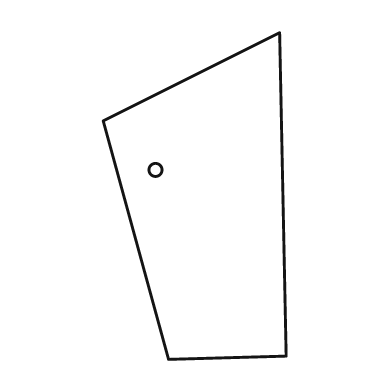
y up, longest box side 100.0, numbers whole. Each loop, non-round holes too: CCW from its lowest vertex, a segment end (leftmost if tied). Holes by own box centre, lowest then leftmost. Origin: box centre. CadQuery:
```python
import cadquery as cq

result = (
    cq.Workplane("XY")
    .moveTo(-8.0, -50.0)
    .lineTo(28.0, -49.0)
    .lineTo(26.0, 50.0)
    .lineTo(-28.0, 23.0)
    .close()
    .moveTo(-12.0, 8.0)
    .circle(2.0)
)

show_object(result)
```